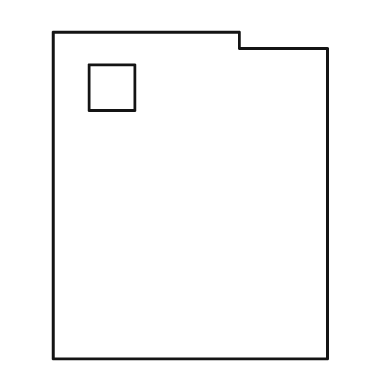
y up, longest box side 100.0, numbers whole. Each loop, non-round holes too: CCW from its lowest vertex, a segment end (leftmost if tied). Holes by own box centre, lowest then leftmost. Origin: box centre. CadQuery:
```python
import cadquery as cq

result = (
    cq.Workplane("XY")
    .moveTo(-42.0, -50.0)
    .lineTo(42.0, -50.0)
    .lineTo(42.0, 45.0)
    .lineTo(15.0, 45.0)
    .lineTo(15.0, 50.0)
    .lineTo(-42.0, 50.0)
    .close()
    .moveTo(-31.0, 26.0)
    .lineTo(-17.0, 26.0)
    .lineTo(-17.0, 40.0)
    .lineTo(-31.0, 40.0)
    .close()
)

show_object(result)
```